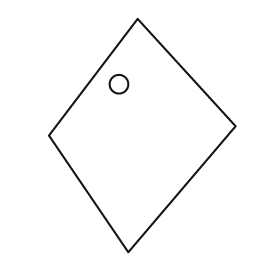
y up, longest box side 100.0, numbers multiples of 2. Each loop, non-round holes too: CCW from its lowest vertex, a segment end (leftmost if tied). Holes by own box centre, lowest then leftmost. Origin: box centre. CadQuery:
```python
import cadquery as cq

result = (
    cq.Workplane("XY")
    .moveTo(-6.0, -50.0)
    .lineTo(40.0, 4.0)
    .lineTo(-2.0, 50.0)
    .lineTo(-40.0, 0.0)
    .close()
    .moveTo(-10.0, 22.0)
    .circle(4.0)
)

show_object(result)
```